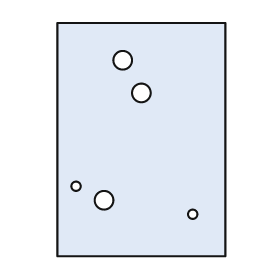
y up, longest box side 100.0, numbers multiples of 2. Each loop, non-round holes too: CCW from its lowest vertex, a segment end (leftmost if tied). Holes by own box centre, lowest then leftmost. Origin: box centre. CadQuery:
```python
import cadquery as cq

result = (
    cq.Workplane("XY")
    .moveTo(-36.0, -50.0)
    .lineTo(36.0, -50.0)
    .lineTo(36.0, 50.0)
    .lineTo(-36.0, 50.0)
    .close()
    .moveTo(22.0, -32.0)
    .circle(2.0)
    .moveTo(-16.0, -26.0)
    .circle(4.0)
    .moveTo(-28.0, -20.0)
    .circle(2.0)
    .moveTo(0.0, 20.0)
    .circle(4.0)
    .moveTo(-8.0, 34.0)
    .circle(4.0)
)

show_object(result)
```